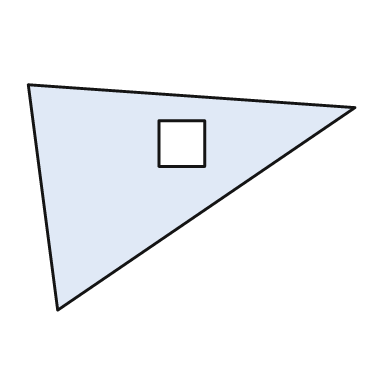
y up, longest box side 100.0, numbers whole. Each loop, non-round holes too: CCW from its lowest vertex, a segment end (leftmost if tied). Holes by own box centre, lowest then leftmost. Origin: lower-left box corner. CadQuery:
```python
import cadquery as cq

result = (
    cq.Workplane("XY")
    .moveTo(9.0, 0.0)
    .lineTo(100.0, 62.0)
    .lineTo(0.0, 69.0)
    .close()
    .moveTo(40.0, 44.0)
    .lineTo(54.0, 44.0)
    .lineTo(54.0, 58.0)
    .lineTo(40.0, 58.0)
    .close()
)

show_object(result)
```